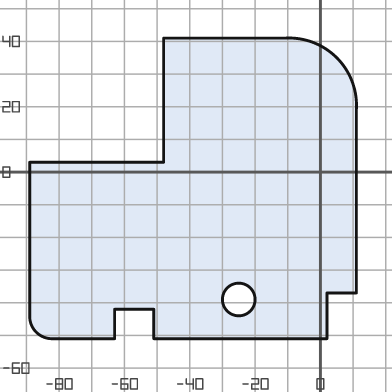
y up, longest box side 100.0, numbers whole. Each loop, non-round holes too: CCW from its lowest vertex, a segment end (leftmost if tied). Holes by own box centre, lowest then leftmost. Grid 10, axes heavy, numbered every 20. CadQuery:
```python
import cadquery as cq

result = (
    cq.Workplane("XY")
    .moveTo(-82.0, -51.0)
    .lineTo(-63.0, -51.0)
    .lineTo(-63.0, -42.0)
    .lineTo(-51.0, -42.0)
    .lineTo(-51.0, -51.0)
    .lineTo(2.0, -51.0)
    .lineTo(2.0, -37.0)
    .lineTo(11.0, -37.0)
    .lineTo(11.0, 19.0)
    .threePointArc((5.0, 35.0), (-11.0, 41.0))
    .lineTo(-48.0, 41.0)
    .lineTo(-48.0, 3.0)
    .lineTo(-89.0, 3.0)
    .lineTo(-89.0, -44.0)
    .threePointArc((-87.0, -49.0), (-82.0, -51.0))
    .close()
    .moveTo(-25.0, -39.0)
    .circle(5.0)
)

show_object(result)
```